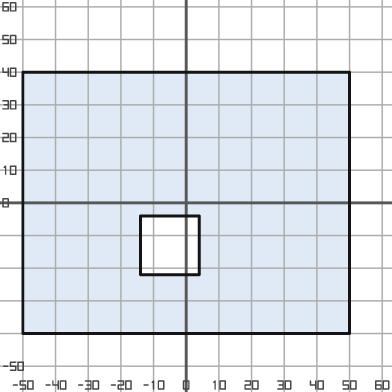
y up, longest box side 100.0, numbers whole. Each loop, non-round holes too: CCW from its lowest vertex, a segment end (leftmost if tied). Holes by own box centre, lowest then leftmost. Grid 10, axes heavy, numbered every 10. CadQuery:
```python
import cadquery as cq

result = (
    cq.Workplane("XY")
    .moveTo(-50.0, -40.0)
    .lineTo(50.0, -40.0)
    .lineTo(50.0, 40.0)
    .lineTo(-50.0, 40.0)
    .close()
    .moveTo(-14.0, -22.0)
    .lineTo(4.0, -22.0)
    .lineTo(4.0, -4.0)
    .lineTo(-14.0, -4.0)
    .close()
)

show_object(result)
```